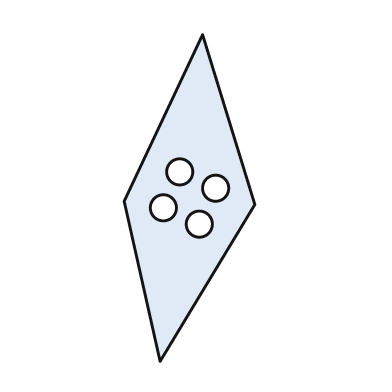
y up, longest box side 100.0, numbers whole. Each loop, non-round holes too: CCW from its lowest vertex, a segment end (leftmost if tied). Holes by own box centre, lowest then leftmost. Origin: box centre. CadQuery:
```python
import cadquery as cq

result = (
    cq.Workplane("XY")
    .moveTo(-9.0, -50.0)
    .lineTo(20.0, -2.0)
    .lineTo(4.0, 50.0)
    .lineTo(-20.0, -1.0)
    .close()
    .moveTo(3.0, -8.0)
    .circle(4.0)
    .moveTo(-8.0, -3.0)
    .circle(4.0)
    .moveTo(8.0, 3.0)
    .circle(4.0)
    .moveTo(-3.0, 8.0)
    .circle(4.0)
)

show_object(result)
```